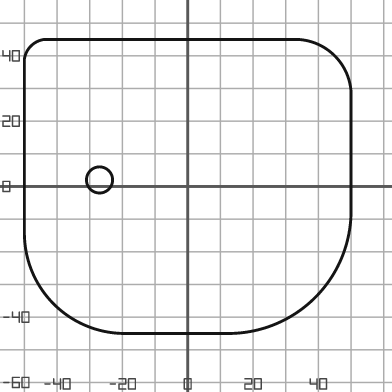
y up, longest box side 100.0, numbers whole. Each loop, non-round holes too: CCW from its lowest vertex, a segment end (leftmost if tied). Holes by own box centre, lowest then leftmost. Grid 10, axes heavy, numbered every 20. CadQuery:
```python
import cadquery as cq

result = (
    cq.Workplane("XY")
    .moveTo(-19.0, -45.0)
    .lineTo(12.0, -45.0)
    .threePointArc((39.0, -34.0), (50.0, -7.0))
    .lineTo(50.0, 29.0)
    .threePointArc((45.0, 40.0), (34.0, 45.0))
    .lineTo(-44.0, 45.0)
    .threePointArc((-48.0, 43.0), (-50.0, 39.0))
    .lineTo(-50.0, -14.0)
    .threePointArc((-41.0, -36.0), (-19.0, -45.0))
    .close()
    .moveTo(-27.0, 2.0)
    .circle(4.0)
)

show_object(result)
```